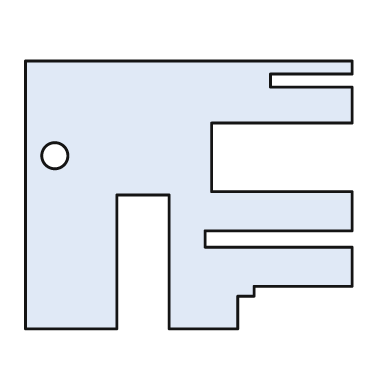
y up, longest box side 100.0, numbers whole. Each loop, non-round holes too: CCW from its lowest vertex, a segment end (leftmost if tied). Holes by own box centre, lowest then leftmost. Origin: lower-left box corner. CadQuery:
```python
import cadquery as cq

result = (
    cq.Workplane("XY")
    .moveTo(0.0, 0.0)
    .lineTo(28.0, 0.0)
    .lineTo(28.0, 41.0)
    .lineTo(44.0, 41.0)
    .lineTo(44.0, 0.0)
    .lineTo(65.0, 0.0)
    .lineTo(65.0, 10.0)
    .lineTo(70.0, 10.0)
    .lineTo(70.0, 13.0)
    .lineTo(100.0, 13.0)
    .lineTo(100.0, 25.0)
    .lineTo(55.0, 25.0)
    .lineTo(55.0, 30.0)
    .lineTo(100.0, 30.0)
    .lineTo(100.0, 42.0)
    .lineTo(57.0, 42.0)
    .lineTo(57.0, 63.0)
    .lineTo(100.0, 63.0)
    .lineTo(100.0, 74.0)
    .lineTo(75.0, 74.0)
    .lineTo(75.0, 78.0)
    .lineTo(100.0, 78.0)
    .lineTo(100.0, 82.0)
    .lineTo(0.0, 82.0)
    .close()
    .moveTo(9.0, 53.0)
    .circle(4.0)
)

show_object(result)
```